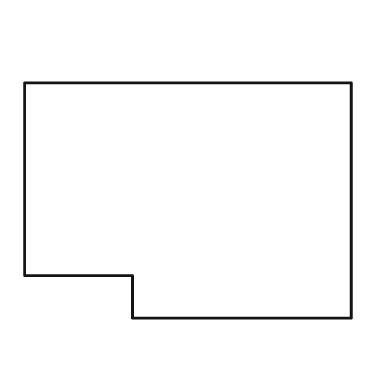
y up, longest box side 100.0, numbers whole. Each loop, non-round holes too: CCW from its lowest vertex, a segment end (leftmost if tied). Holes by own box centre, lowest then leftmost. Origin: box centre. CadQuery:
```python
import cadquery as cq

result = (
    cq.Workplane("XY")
    .moveTo(-17.0, -36.0)
    .lineTo(50.0, -36.0)
    .lineTo(50.0, 36.0)
    .lineTo(-50.0, 36.0)
    .lineTo(-50.0, -23.0)
    .lineTo(-17.0, -23.0)
    .close()
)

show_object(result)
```